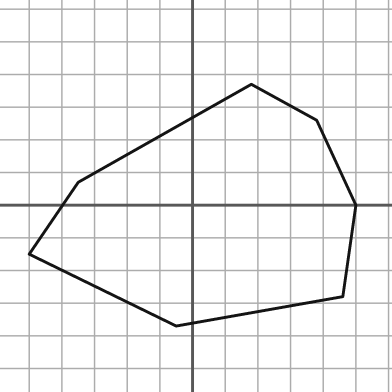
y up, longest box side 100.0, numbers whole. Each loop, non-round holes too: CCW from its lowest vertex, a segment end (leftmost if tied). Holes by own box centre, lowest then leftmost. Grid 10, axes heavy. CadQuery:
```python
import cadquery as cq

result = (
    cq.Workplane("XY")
    .moveTo(-5.0, -37.0)
    .lineTo(46.0, -28.0)
    .lineTo(50.0, 0.0)
    .lineTo(38.0, 26.0)
    .lineTo(18.0, 37.0)
    .lineTo(-35.0, 7.0)
    .lineTo(-50.0, -15.0)
    .close()
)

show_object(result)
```